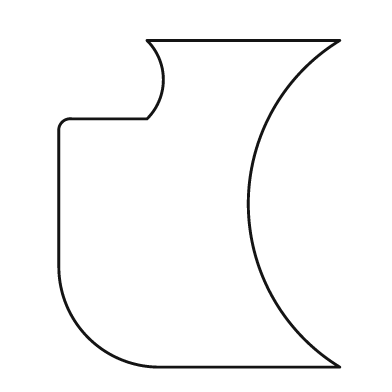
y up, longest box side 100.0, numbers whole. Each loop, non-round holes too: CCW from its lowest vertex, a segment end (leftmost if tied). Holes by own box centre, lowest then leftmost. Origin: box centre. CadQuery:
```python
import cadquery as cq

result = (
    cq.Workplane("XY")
    .moveTo(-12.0, -50.0)
    .lineTo(43.0, -50.0)
    .threePointArc((15.0, 0.0), (43.0, 50.0))
    .lineTo(-16.0, 50.0)
    .threePointArc((-11.0, 38.0), (-16.0, 26.0))
    .lineTo(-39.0, 26.0)
    .threePointArc((-42.0, 25.0), (-43.0, 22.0))
    .lineTo(-43.0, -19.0)
    .threePointArc((-34.0, -41.0), (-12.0, -50.0))
    .close()
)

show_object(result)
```